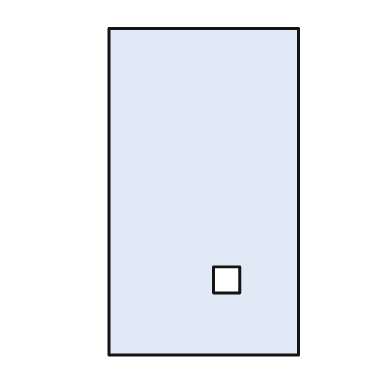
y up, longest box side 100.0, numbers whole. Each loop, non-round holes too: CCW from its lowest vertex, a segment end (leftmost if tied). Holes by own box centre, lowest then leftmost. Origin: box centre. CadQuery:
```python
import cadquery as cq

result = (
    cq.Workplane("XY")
    .moveTo(-29.0, -50.0)
    .lineTo(29.0, -50.0)
    .lineTo(29.0, 50.0)
    .lineTo(-29.0, 50.0)
    .close()
    .moveTo(3.0, -31.0)
    .lineTo(11.0, -31.0)
    .lineTo(11.0, -23.0)
    .lineTo(3.0, -23.0)
    .close()
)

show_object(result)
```